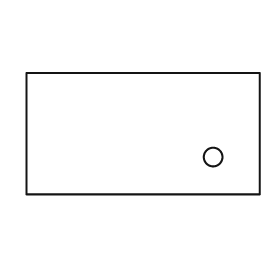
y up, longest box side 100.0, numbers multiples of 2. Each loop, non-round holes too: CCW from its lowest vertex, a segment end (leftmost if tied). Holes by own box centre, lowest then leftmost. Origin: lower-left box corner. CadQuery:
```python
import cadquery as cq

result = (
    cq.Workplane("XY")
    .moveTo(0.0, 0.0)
    .lineTo(100.0, 0.0)
    .lineTo(100.0, 52.0)
    .lineTo(0.0, 52.0)
    .close()
    .moveTo(80.0, 16.0)
    .circle(4.0)
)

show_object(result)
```